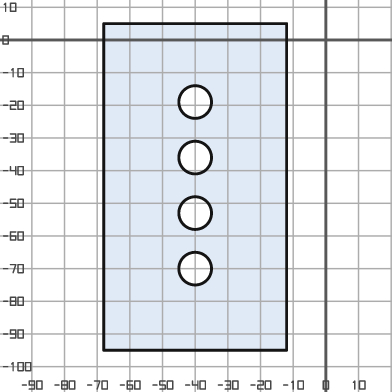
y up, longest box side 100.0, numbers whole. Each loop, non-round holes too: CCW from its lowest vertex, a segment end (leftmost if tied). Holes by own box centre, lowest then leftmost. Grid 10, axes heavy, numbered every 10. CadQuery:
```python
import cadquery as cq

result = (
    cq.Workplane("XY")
    .moveTo(-68.0, -95.0)
    .lineTo(-12.0, -95.0)
    .lineTo(-12.0, 5.0)
    .lineTo(-68.0, 5.0)
    .close()
    .moveTo(-40.0, -70.0)
    .circle(5.0)
    .moveTo(-40.0, -53.0)
    .circle(5.0)
    .moveTo(-40.0, -36.0)
    .circle(5.0)
    .moveTo(-40.0, -19.0)
    .circle(5.0)
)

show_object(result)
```